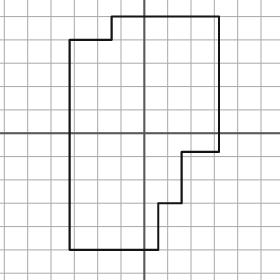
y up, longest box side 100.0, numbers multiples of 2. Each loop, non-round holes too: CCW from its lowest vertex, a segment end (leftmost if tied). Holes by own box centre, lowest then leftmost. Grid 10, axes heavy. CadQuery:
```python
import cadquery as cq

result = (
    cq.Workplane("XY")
    .moveTo(-32.0, -50.0)
    .lineTo(6.0, -50.0)
    .lineTo(6.0, -30.0)
    .lineTo(16.0, -30.0)
    .lineTo(16.0, -8.0)
    .lineTo(32.0, -8.0)
    .lineTo(32.0, 50.0)
    .lineTo(-14.0, 50.0)
    .lineTo(-14.0, 40.0)
    .lineTo(-32.0, 40.0)
    .close()
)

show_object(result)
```